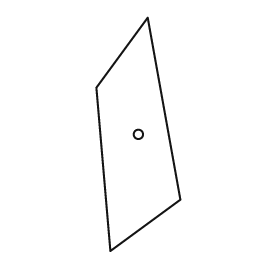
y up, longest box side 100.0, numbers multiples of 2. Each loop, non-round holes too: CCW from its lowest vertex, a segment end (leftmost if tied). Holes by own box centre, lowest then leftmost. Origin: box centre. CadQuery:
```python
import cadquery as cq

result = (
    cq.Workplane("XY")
    .moveTo(-12.0, -50.0)
    .lineTo(18.0, -28.0)
    .lineTo(4.0, 50.0)
    .lineTo(-18.0, 20.0)
    .close()
    .moveTo(0.0, 0.0)
    .circle(2.0)
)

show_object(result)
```